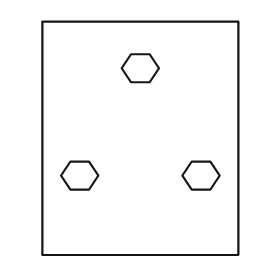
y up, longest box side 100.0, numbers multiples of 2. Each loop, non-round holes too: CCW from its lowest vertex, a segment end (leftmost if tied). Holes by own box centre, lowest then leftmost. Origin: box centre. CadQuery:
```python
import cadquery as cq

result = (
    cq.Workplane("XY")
    .moveTo(-42.0, -50.0)
    .lineTo(42.0, -50.0)
    .lineTo(42.0, 50.0)
    .lineTo(-42.0, 50.0)
    .close()
    .moveTo(-30.0, -22.0)
    .lineTo(-22.0, -22.0)
    .lineTo(-18.0, -16.0)
    .lineTo(-22.0, -10.0)
    .lineTo(-30.0, -10.0)
    .lineTo(-34.0, -16.0)
    .close()
    .moveTo(22.0, -22.0)
    .lineTo(30.0, -22.0)
    .lineTo(34.0, -16.0)
    .lineTo(30.0, -10.0)
    .lineTo(22.0, -10.0)
    .lineTo(18.0, -16.0)
    .close()
    .moveTo(-4.0, 24.0)
    .lineTo(4.0, 24.0)
    .lineTo(8.0, 30.0)
    .lineTo(4.0, 36.0)
    .lineTo(-4.0, 36.0)
    .lineTo(-8.0, 30.0)
    .close()
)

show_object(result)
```